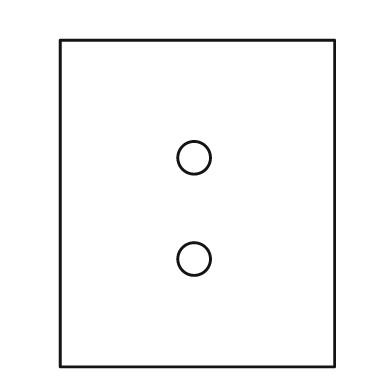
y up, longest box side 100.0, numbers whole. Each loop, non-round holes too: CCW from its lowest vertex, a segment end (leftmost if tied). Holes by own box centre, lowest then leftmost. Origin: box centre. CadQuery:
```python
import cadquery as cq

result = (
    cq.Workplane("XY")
    .moveTo(-42.0, -50.0)
    .lineTo(42.0, -50.0)
    .lineTo(42.0, 50.0)
    .lineTo(-42.0, 50.0)
    .close()
    .moveTo(-1.0, -17.0)
    .circle(5.0)
    .moveTo(-1.0, 14.0)
    .circle(5.0)
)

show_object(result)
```